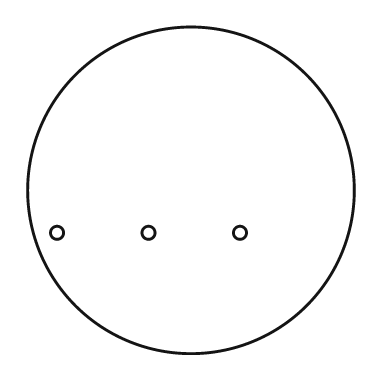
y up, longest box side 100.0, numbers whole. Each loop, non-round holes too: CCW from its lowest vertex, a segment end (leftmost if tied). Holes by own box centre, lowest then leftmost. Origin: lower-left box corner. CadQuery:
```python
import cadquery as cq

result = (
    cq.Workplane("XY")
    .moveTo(50.0, 50.0)
    .circle(50.0)
    .moveTo(9.0, 37.0)
    .circle(2.0)
    .moveTo(37.0, 37.0)
    .circle(2.0)
    .moveTo(65.0, 37.0)
    .circle(2.0)
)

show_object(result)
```